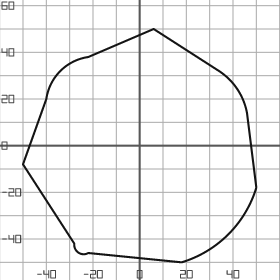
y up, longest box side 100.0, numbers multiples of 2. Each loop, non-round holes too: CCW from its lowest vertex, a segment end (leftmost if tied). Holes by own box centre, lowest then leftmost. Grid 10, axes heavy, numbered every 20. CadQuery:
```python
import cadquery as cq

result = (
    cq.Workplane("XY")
    .moveTo(18.0, -50.0)
    .threePointArc((38.0, -38.0), (50.0, -18.0))
    .lineTo(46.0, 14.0)
    .threePointArc((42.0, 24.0), (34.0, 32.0))
    .lineTo(6.0, 50.0)
    .lineTo(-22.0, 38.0)
    .threePointArc((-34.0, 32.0), (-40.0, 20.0))
    .lineTo(-50.0, -8.0)
    .lineTo(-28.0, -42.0)
    .threePointArc((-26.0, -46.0), (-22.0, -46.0))
    .close()
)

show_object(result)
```